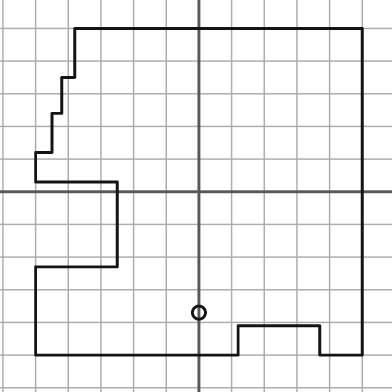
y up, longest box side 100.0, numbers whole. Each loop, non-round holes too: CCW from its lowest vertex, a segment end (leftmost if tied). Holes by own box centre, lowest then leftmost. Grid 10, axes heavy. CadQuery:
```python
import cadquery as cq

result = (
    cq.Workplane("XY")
    .moveTo(-50.0, -50.0)
    .lineTo(12.0, -50.0)
    .lineTo(12.0, -41.0)
    .lineTo(37.0, -41.0)
    .lineTo(37.0, -50.0)
    .lineTo(50.0, -50.0)
    .lineTo(50.0, 50.0)
    .lineTo(-38.0, 50.0)
    .lineTo(-38.0, 35.0)
    .lineTo(-42.0, 35.0)
    .lineTo(-42.0, 24.0)
    .lineTo(-45.0, 24.0)
    .lineTo(-45.0, 12.0)
    .lineTo(-50.0, 12.0)
    .lineTo(-50.0, 3.0)
    .lineTo(-25.0, 3.0)
    .lineTo(-25.0, -23.0)
    .lineTo(-50.0, -23.0)
    .close()
    .moveTo(0.0, -37.0)
    .circle(2.0)
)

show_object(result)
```